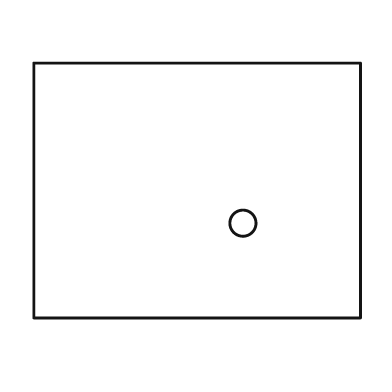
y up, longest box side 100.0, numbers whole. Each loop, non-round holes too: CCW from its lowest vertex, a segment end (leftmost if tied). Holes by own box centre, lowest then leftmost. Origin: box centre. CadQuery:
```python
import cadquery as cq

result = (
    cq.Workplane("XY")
    .moveTo(-50.0, -39.0)
    .lineTo(50.0, -39.0)
    .lineTo(50.0, 39.0)
    .lineTo(-50.0, 39.0)
    .close()
    .moveTo(14.0, -10.0)
    .circle(4.0)
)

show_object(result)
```